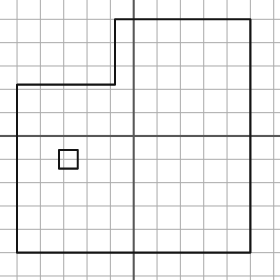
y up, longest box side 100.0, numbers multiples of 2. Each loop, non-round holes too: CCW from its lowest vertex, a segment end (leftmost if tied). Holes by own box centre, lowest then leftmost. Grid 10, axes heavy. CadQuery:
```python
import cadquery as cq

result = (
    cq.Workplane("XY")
    .moveTo(-50.0, -50.0)
    .lineTo(50.0, -50.0)
    .lineTo(50.0, 50.0)
    .lineTo(-8.0, 50.0)
    .lineTo(-8.0, 22.0)
    .lineTo(-50.0, 22.0)
    .close()
    .moveTo(-32.0, -14.0)
    .lineTo(-24.0, -14.0)
    .lineTo(-24.0, -6.0)
    .lineTo(-32.0, -6.0)
    .close()
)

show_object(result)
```